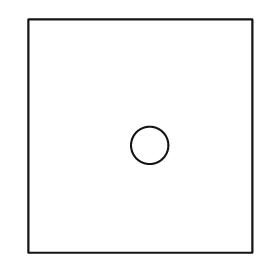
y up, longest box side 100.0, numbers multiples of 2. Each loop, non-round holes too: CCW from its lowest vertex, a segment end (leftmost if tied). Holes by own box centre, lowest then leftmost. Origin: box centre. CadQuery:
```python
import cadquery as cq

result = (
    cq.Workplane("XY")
    .moveTo(-48.0, -50.0)
    .lineTo(48.0, -50.0)
    .lineTo(48.0, 50.0)
    .lineTo(-48.0, 50.0)
    .close()
    .moveTo(4.0, -4.0)
    .circle(8.0)
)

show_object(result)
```